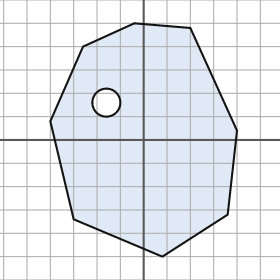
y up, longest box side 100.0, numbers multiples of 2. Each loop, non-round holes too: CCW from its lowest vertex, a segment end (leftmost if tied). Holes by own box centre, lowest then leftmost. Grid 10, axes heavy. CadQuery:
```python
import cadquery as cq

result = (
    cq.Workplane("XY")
    .moveTo(8.0, -50.0)
    .lineTo(36.0, -32.0)
    .lineTo(40.0, 4.0)
    .lineTo(20.0, 48.0)
    .lineTo(-4.0, 50.0)
    .lineTo(-26.0, 40.0)
    .lineTo(-40.0, 8.0)
    .lineTo(-30.0, -34.0)
    .close()
    .moveTo(-16.0, 16.0)
    .circle(6.0)
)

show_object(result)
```